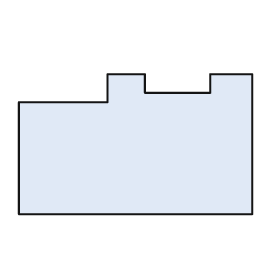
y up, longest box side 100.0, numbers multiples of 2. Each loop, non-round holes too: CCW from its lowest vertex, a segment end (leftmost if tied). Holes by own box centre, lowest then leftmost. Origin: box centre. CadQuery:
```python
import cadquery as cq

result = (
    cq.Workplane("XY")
    .moveTo(-50.0, -30.0)
    .lineTo(50.0, -30.0)
    .lineTo(50.0, 30.0)
    .lineTo(32.0, 30.0)
    .lineTo(32.0, 22.0)
    .lineTo(4.0, 22.0)
    .lineTo(4.0, 30.0)
    .lineTo(-12.0, 30.0)
    .lineTo(-12.0, 18.0)
    .lineTo(-50.0, 18.0)
    .close()
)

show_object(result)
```